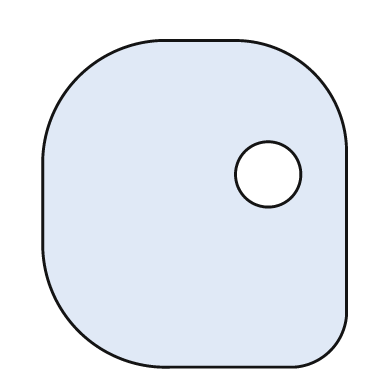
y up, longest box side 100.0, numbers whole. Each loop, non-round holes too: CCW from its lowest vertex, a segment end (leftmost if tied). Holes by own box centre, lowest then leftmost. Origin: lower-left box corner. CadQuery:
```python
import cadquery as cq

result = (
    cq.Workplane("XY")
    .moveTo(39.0, 0.0)
    .lineTo(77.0, 0.0)
    .threePointArc((88.0, 5.0), (93.0, 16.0))
    .lineTo(93.0, 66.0)
    .threePointArc((83.0, 90.0), (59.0, 100.0))
    .lineTo(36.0, 100.0)
    .threePointArc((11.0, 89.0), (0.0, 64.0))
    .lineTo(0.0, 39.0)
    .threePointArc((11.0, 11.0), (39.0, 0.0))
    .close()
    .moveTo(69.0, 59.0)
    .circle(10.0)
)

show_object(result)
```